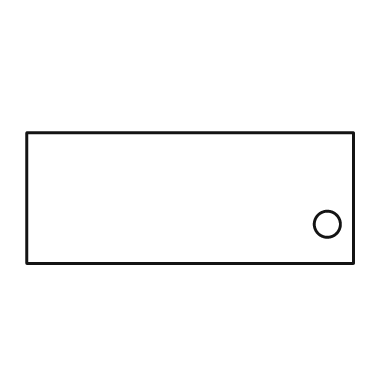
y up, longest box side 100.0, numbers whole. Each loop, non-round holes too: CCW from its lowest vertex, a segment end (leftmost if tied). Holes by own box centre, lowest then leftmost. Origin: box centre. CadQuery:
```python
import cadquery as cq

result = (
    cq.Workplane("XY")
    .moveTo(-50.0, -20.0)
    .lineTo(50.0, -20.0)
    .lineTo(50.0, 20.0)
    .lineTo(-50.0, 20.0)
    .close()
    .moveTo(42.0, -8.0)
    .circle(4.0)
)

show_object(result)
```